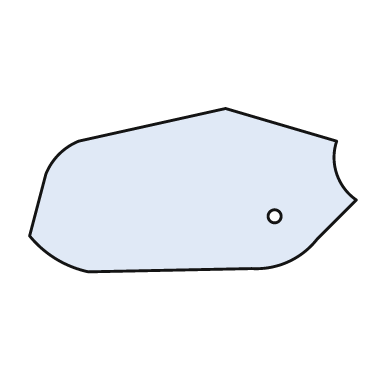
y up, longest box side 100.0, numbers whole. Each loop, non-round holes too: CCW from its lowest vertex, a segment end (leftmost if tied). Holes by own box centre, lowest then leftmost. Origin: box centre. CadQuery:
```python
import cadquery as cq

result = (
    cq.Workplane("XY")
    .moveTo(-32.0, -25.0)
    .lineTo(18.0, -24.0)
    .threePointArc((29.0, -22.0), (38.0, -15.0))
    .lineTo(50.0, -3.0)
    .threePointArc((44.0, 5.0), (44.0, 15.0))
    .lineTo(10.0, 25.0)
    .lineTo(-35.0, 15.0)
    .threePointArc((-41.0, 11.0), (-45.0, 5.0))
    .lineTo(-50.0, -14.0)
    .threePointArc((-42.0, -21.0), (-32.0, -25.0))
    .close()
    .moveTo(25.0, -8.0)
    .circle(2.0)
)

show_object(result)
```